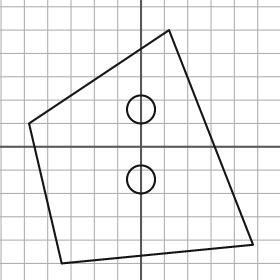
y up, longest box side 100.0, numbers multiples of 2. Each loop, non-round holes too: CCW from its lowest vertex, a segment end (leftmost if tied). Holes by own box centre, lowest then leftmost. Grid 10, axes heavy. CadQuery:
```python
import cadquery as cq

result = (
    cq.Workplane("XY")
    .moveTo(-34.0, -50.0)
    .lineTo(48.0, -42.0)
    .lineTo(12.0, 50.0)
    .lineTo(-48.0, 10.0)
    .close()
    .moveTo(0.0, -14.0)
    .circle(6.0)
    .moveTo(0.0, 16.0)
    .circle(6.0)
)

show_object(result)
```